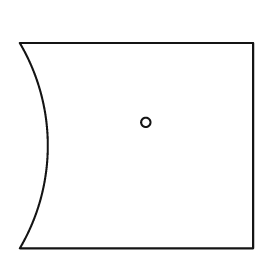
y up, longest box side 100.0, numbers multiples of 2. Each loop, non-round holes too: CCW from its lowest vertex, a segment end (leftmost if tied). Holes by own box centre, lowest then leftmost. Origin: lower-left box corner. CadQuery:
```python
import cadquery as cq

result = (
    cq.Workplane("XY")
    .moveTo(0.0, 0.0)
    .lineTo(100.0, 0.0)
    .lineTo(100.0, 88.0)
    .lineTo(0.0, 88.0)
    .threePointArc((12.0, 44.0), (0.0, 0.0))
    .close()
    .moveTo(54.0, 54.0)
    .circle(2.0)
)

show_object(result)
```